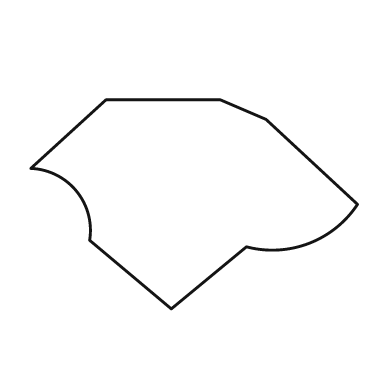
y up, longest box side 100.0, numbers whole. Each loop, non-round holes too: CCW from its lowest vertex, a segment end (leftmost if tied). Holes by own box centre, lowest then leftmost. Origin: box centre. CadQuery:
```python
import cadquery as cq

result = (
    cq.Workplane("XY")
    .moveTo(-7.0, -32.0)
    .lineTo(16.0, -13.0)
    .threePointArc((35.0, -12.0), (50.0, 0.0))
    .lineTo(22.0, 26.0)
    .lineTo(8.0, 32.0)
    .lineTo(-27.0, 32.0)
    .lineTo(-50.0, 11.0)
    .threePointArc((-36.0, 4.0), (-32.0, -11.0))
    .close()
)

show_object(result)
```